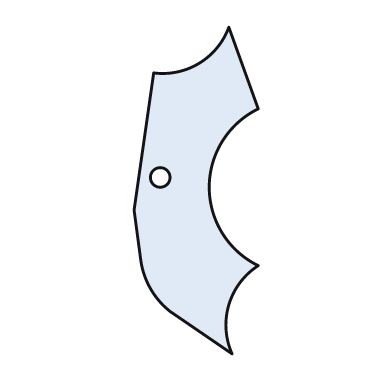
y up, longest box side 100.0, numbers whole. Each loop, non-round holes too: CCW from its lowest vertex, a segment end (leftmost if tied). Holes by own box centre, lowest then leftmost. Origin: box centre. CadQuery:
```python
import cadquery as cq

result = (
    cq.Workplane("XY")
    .moveTo(11.0, -50.0)
    .threePointArc((10.0, -35.0), (19.0, -23.0))
    .threePointArc((4.0, 1.0), (19.0, 25.0))
    .lineTo(10.0, 50.0)
    .threePointArc((1.0, 39.0), (-13.0, 36.0))
    .lineTo(-19.0, -6.0)
    .lineTo(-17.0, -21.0)
    .threePointArc((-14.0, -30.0), (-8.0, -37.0))
    .close()
    .moveTo(-11.0, 4.0)
    .circle(3.0)
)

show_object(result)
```